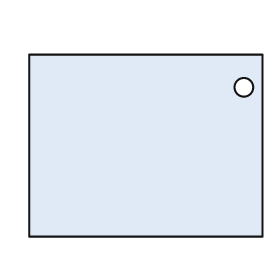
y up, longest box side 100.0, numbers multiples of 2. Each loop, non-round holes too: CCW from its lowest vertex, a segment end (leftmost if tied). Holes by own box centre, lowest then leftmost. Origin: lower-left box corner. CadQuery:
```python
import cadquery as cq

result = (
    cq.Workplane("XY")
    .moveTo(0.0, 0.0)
    .lineTo(100.0, 0.0)
    .lineTo(100.0, 78.0)
    .lineTo(0.0, 78.0)
    .close()
    .moveTo(92.0, 64.0)
    .circle(4.0)
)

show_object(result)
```